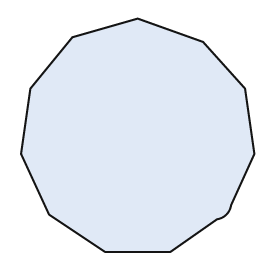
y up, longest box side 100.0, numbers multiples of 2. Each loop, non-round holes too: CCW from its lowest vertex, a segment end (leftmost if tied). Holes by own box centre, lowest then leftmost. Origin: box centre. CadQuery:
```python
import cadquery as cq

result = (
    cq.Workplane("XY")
    .moveTo(-14.0, -50.0)
    .lineTo(14.0, -50.0)
    .lineTo(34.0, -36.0)
    .threePointArc((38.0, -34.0), (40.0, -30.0))
    .lineTo(50.0, -8.0)
    .lineTo(46.0, 20.0)
    .lineTo(28.0, 40.0)
    .lineTo(0.0, 50.0)
    .lineTo(-28.0, 42.0)
    .lineTo(-46.0, 20.0)
    .lineTo(-50.0, -8.0)
    .lineTo(-38.0, -34.0)
    .close()
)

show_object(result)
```